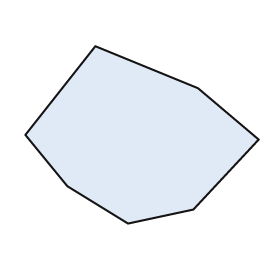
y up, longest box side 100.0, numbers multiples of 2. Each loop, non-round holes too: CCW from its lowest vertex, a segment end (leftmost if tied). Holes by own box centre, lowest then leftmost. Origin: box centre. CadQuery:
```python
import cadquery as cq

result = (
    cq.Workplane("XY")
    .moveTo(-6.0, -38.0)
    .lineTo(22.0, -32.0)
    .lineTo(50.0, -2.0)
    .lineTo(24.0, 20.0)
    .lineTo(-20.0, 38.0)
    .lineTo(-50.0, 0.0)
    .lineTo(-32.0, -22.0)
    .close()
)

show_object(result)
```